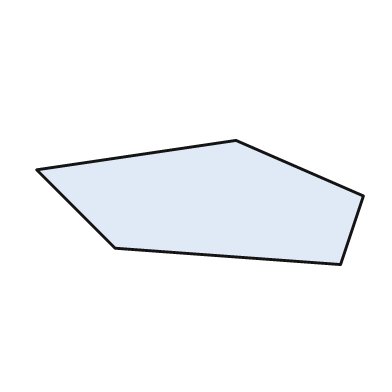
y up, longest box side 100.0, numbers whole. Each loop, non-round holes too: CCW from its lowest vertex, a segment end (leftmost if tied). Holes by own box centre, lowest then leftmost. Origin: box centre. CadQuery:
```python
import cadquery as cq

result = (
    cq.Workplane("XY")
    .moveTo(43.0, -19.0)
    .lineTo(50.0, 2.0)
    .lineTo(11.0, 19.0)
    .lineTo(-50.0, 10.0)
    .lineTo(-26.0, -14.0)
    .close()
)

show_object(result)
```